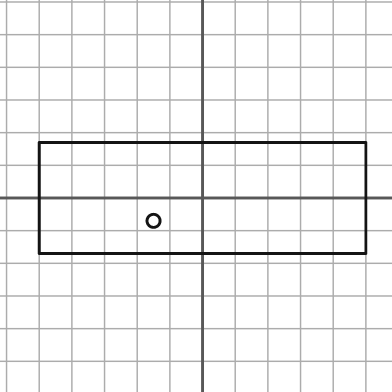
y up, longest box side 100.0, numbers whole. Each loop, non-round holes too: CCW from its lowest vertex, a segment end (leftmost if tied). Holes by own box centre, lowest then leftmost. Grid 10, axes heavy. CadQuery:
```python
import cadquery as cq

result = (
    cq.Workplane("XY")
    .moveTo(-50.0, -17.0)
    .lineTo(50.0, -17.0)
    .lineTo(50.0, 17.0)
    .lineTo(-50.0, 17.0)
    .close()
    .moveTo(-15.0, -7.0)
    .circle(2.0)
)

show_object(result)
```